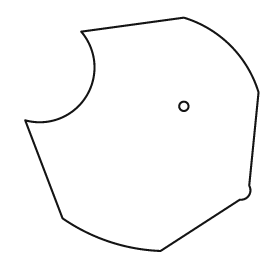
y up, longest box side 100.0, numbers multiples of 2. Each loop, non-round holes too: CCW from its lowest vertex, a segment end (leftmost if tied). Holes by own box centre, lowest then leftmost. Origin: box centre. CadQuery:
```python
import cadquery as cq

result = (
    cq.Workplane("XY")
    .moveTo(8.0, -50.0)
    .lineTo(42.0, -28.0)
    .threePointArc((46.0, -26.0), (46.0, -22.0))
    .lineTo(50.0, 18.0)
    .threePointArc((38.0, 38.0), (18.0, 50.0))
    .lineTo(-26.0, 44.0)
    .threePointArc((-24.0, 16.0), (-50.0, 6.0))
    .lineTo(-34.0, -36.0)
    .threePointArc((-14.0, -46.0), (8.0, -50.0))
    .close()
    .moveTo(18.0, 12.0)
    .circle(2.0)
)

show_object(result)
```